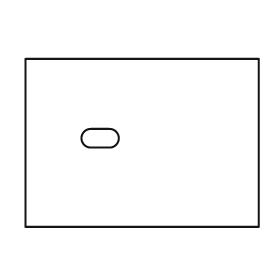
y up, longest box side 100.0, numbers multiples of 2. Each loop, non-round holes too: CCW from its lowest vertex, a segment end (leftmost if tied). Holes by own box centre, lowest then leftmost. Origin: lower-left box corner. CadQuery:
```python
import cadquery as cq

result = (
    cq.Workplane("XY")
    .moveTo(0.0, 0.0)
    .lineTo(100.0, 0.0)
    .lineTo(100.0, 72.0)
    .lineTo(0.0, 72.0)
    .close()
    .moveTo(28.0, 34.0)
    .lineTo(36.0, 34.0)
    .threePointArc((40.0, 38.0), (36.0, 42.0))
    .lineTo(28.0, 42.0)
    .threePointArc((24.0, 38.0), (28.0, 34.0))
    .close()
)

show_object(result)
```